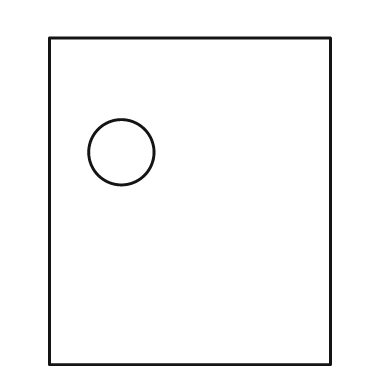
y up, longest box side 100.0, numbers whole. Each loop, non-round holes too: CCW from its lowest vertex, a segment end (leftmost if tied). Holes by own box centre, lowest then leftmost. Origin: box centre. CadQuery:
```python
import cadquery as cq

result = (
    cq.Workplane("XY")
    .moveTo(-43.0, -50.0)
    .lineTo(43.0, -50.0)
    .lineTo(43.0, 50.0)
    .lineTo(-43.0, 50.0)
    .close()
    .moveTo(-21.0, 15.0)
    .circle(10.0)
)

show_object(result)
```